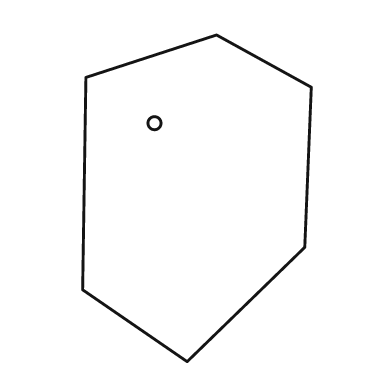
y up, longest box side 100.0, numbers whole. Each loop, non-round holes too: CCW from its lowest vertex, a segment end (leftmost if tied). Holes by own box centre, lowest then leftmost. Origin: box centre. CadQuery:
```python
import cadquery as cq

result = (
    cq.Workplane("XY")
    .moveTo(-3.0, -50.0)
    .lineTo(33.0, -15.0)
    .lineTo(35.0, 34.0)
    .lineTo(6.0, 50.0)
    .lineTo(-34.0, 37.0)
    .lineTo(-35.0, -28.0)
    .close()
    .moveTo(-13.0, 23.0)
    .circle(2.0)
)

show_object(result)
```